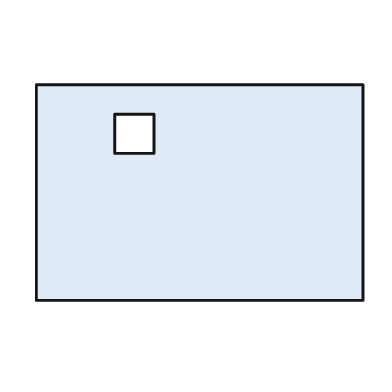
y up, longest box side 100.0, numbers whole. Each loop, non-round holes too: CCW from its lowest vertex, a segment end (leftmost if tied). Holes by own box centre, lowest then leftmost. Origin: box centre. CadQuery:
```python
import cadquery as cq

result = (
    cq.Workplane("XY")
    .moveTo(-50.0, -33.0)
    .lineTo(50.0, -33.0)
    .lineTo(50.0, 33.0)
    .lineTo(-50.0, 33.0)
    .close()
    .moveTo(-26.0, 12.0)
    .lineTo(-14.0, 12.0)
    .lineTo(-14.0, 24.0)
    .lineTo(-26.0, 24.0)
    .close()
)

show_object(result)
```